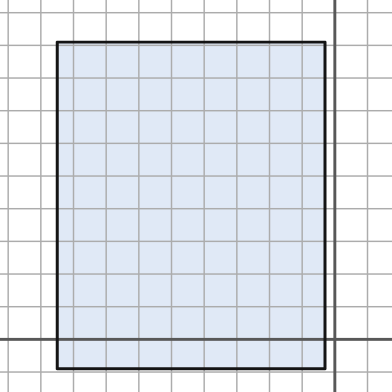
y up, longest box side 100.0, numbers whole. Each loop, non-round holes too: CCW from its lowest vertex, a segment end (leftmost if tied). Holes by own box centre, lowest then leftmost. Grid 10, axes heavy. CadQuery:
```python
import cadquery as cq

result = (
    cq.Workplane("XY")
    .moveTo(-85.0, -9.0)
    .lineTo(-3.0, -9.0)
    .lineTo(-3.0, 91.0)
    .lineTo(-85.0, 91.0)
    .close()
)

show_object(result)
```